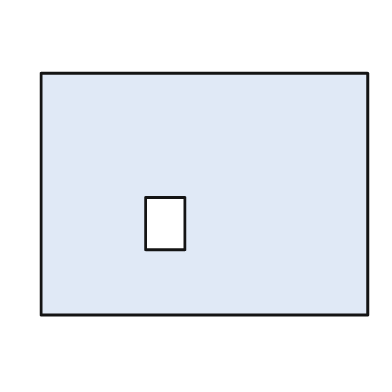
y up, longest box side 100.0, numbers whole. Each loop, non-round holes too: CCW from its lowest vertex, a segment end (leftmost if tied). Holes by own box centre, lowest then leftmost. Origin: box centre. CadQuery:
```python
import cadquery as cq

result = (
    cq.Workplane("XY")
    .moveTo(-50.0, -37.0)
    .lineTo(50.0, -37.0)
    .lineTo(50.0, 37.0)
    .lineTo(-50.0, 37.0)
    .close()
    .moveTo(-18.0, -17.0)
    .lineTo(-6.0, -17.0)
    .lineTo(-6.0, -1.0)
    .lineTo(-18.0, -1.0)
    .close()
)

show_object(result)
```